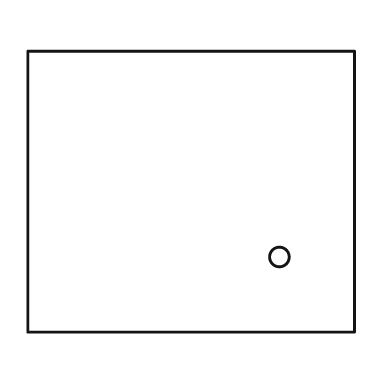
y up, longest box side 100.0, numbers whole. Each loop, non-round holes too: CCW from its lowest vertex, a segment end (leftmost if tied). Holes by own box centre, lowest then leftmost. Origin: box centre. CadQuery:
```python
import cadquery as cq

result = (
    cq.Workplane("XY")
    .moveTo(-50.0, -43.0)
    .lineTo(50.0, -43.0)
    .lineTo(50.0, 43.0)
    .lineTo(-50.0, 43.0)
    .close()
    .moveTo(27.0, -20.0)
    .circle(3.0)
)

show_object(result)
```